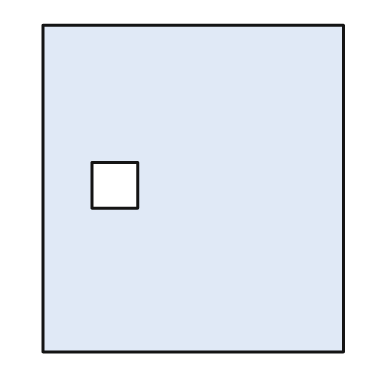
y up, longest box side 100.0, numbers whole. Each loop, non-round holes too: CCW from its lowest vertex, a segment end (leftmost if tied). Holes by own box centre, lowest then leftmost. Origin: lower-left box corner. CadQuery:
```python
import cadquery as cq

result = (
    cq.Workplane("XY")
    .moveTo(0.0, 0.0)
    .lineTo(92.0, 0.0)
    .lineTo(92.0, 100.0)
    .lineTo(0.0, 100.0)
    .close()
    .moveTo(15.0, 44.0)
    .lineTo(29.0, 44.0)
    .lineTo(29.0, 58.0)
    .lineTo(15.0, 58.0)
    .close()
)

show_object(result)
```